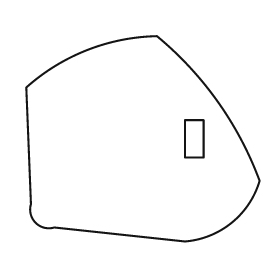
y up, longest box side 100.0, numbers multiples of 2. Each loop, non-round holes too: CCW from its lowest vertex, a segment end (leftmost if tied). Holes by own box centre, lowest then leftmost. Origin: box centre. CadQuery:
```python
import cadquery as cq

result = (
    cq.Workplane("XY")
    .moveTo(18.0, -44.0)
    .threePointArc((38.0, -36.0), (50.0, -18.0))
    .threePointArc((32.0, 16.0), (6.0, 44.0))
    .threePointArc((-24.0, 38.0), (-50.0, 22.0))
    .lineTo(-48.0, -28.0)
    .threePointArc((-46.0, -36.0), (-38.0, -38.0))
    .close()
    .moveTo(18.0, -8.0)
    .lineTo(26.0, -8.0)
    .lineTo(26.0, 8.0)
    .lineTo(18.0, 8.0)
    .close()
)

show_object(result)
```